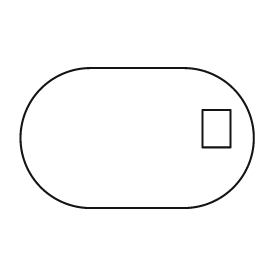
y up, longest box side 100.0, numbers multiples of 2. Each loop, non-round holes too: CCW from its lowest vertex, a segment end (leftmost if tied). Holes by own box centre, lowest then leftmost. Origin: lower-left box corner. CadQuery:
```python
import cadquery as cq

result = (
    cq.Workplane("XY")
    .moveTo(30.0, 0.0)
    .lineTo(70.0, 0.0)
    .threePointArc((100.0, 30.0), (70.0, 60.0))
    .lineTo(30.0, 60.0)
    .threePointArc((0.0, 30.0), (30.0, 0.0))
    .close()
    .moveTo(78.0, 26.0)
    .lineTo(90.0, 26.0)
    .lineTo(90.0, 42.0)
    .lineTo(78.0, 42.0)
    .close()
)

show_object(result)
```